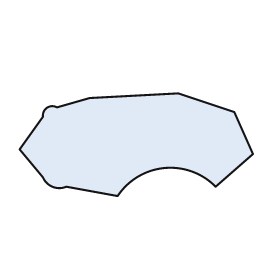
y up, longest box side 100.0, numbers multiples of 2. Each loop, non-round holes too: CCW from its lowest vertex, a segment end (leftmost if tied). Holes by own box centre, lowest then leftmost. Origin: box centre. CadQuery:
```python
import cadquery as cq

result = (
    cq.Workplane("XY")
    .moveTo(-8.0, -22.0)
    .threePointArc((12.0, -10.0), (34.0, -18.0))
    .lineTo(50.0, -4.0)
    .lineTo(42.0, 14.0)
    .lineTo(18.0, 22.0)
    .lineTo(-20.0, 20.0)
    .lineTo(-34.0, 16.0)
    .threePointArc((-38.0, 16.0), (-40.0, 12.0))
    .lineTo(-50.0, -2.0)
    .lineTo(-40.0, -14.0)
    .threePointArc((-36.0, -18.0), (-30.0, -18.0))
    .close()
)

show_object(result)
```